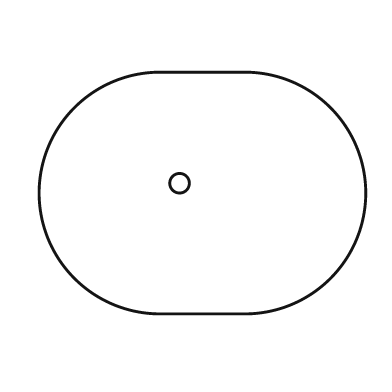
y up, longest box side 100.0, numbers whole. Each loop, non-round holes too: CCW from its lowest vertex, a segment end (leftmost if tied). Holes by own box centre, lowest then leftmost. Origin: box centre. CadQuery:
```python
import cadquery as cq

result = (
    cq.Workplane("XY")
    .moveTo(-13.0, -37.0)
    .lineTo(13.0, -37.0)
    .threePointArc((50.0, 0.0), (13.0, 37.0))
    .lineTo(-13.0, 37.0)
    .threePointArc((-50.0, 0.0), (-13.0, -37.0))
    .close()
    .moveTo(-7.0, 3.0)
    .circle(3.0)
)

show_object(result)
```